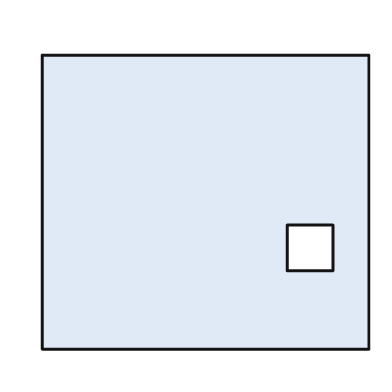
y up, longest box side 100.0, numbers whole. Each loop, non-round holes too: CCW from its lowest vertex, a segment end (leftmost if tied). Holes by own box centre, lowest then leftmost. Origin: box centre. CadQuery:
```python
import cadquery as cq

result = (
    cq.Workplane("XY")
    .moveTo(-50.0, -45.0)
    .lineTo(50.0, -45.0)
    .lineTo(50.0, 45.0)
    .lineTo(-50.0, 45.0)
    .close()
    .moveTo(25.0, -21.0)
    .lineTo(39.0, -21.0)
    .lineTo(39.0, -7.0)
    .lineTo(25.0, -7.0)
    .close()
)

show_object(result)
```